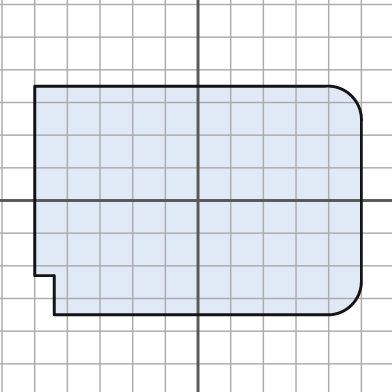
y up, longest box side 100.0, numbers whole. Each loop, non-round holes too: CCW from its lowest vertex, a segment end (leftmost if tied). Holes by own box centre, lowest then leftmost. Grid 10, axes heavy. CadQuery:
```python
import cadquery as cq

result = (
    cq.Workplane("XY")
    .moveTo(-44.0, -35.0)
    .lineTo(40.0, -35.0)
    .threePointArc((47.0, -32.0), (50.0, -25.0))
    .lineTo(50.0, 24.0)
    .threePointArc((47.0, 32.0), (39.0, 35.0))
    .lineTo(-50.0, 35.0)
    .lineTo(-50.0, -23.0)
    .lineTo(-44.0, -23.0)
    .close()
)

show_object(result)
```